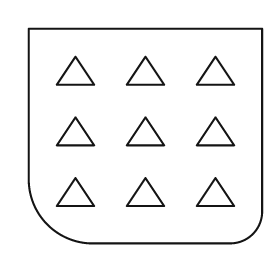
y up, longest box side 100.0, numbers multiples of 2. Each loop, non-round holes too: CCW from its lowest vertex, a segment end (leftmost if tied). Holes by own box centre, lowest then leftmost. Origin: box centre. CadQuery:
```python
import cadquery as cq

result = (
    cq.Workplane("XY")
    .moveTo(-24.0, -46.0)
    .lineTo(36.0, -46.0)
    .threePointArc((46.0, -42.0), (50.0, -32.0))
    .lineTo(50.0, 46.0)
    .lineTo(-50.0, 46.0)
    .lineTo(-50.0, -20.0)
    .threePointArc((-42.0, -38.0), (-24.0, -46.0))
    .close()
    .moveTo(-38.0, -30.0)
    .lineTo(-22.0, -30.0)
    .lineTo(-30.0, -18.0)
    .close()
    .moveTo(-8.0, -30.0)
    .lineTo(8.0, -30.0)
    .lineTo(0.0, -18.0)
    .close()
    .moveTo(22.0, -30.0)
    .lineTo(38.0, -30.0)
    .lineTo(30.0, -18.0)
    .close()
    .moveTo(-38.0, -4.0)
    .lineTo(-22.0, -4.0)
    .lineTo(-30.0, 8.0)
    .close()
    .moveTo(-8.0, -4.0)
    .lineTo(8.0, -4.0)
    .lineTo(0.0, 8.0)
    .close()
    .moveTo(22.0, -4.0)
    .lineTo(38.0, -4.0)
    .lineTo(30.0, 8.0)
    .close()
    .moveTo(-38.0, 22.0)
    .lineTo(-22.0, 22.0)
    .lineTo(-30.0, 34.0)
    .close()
    .moveTo(-8.0, 22.0)
    .lineTo(8.0, 22.0)
    .lineTo(0.0, 34.0)
    .close()
    .moveTo(22.0, 22.0)
    .lineTo(38.0, 22.0)
    .lineTo(30.0, 34.0)
    .close()
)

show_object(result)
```